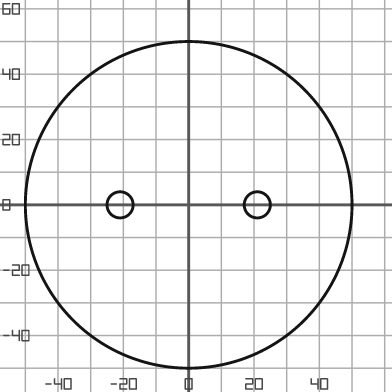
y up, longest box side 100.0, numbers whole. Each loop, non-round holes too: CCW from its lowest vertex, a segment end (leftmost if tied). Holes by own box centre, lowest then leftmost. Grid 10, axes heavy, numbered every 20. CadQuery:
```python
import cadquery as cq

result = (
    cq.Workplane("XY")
    .moveTo(0.0, 0.0)
    .circle(50.0)
    .moveTo(-21.0, 0.0)
    .circle(4.0)
    .moveTo(21.0, 0.0)
    .circle(4.0)
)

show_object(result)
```